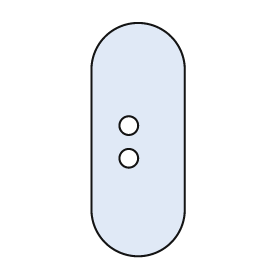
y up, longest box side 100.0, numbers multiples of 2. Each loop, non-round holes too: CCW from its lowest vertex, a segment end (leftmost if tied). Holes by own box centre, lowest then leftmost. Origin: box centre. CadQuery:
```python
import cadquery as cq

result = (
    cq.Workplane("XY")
    .moveTo(-20.0, -30.0)
    .threePointArc((0.0, -50.0), (20.0, -30.0))
    .lineTo(20.0, 30.0)
    .threePointArc((0.0, 50.0), (-20.0, 30.0))
    .close()
    .moveTo(-4.0, -8.0)
    .circle(4.0)
    .moveTo(-4.0, 6.0)
    .circle(4.0)
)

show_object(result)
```